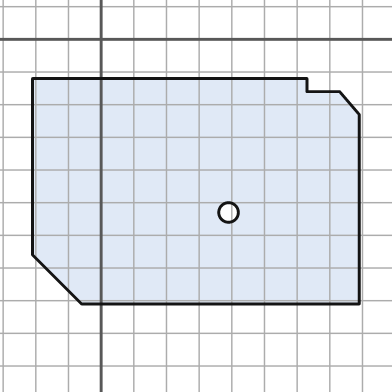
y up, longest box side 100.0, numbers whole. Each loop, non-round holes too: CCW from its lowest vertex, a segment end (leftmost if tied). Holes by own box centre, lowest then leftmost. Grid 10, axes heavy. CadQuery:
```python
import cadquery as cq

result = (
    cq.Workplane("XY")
    .moveTo(-6.0, -81.0)
    .lineTo(79.0, -81.0)
    .lineTo(79.0, -23.0)
    .lineTo(73.0, -16.0)
    .lineTo(63.0, -16.0)
    .lineTo(63.0, -12.0)
    .lineTo(-21.0, -12.0)
    .lineTo(-21.0, -66.0)
    .close()
    .moveTo(39.0, -53.0)
    .circle(3.0)
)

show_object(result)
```